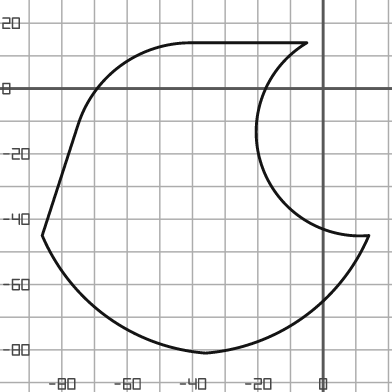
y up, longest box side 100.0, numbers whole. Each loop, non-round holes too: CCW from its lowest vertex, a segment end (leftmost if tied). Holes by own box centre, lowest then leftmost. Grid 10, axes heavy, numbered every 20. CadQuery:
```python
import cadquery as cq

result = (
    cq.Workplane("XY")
    .moveTo(-36.0, -81.0)
    .threePointArc((-6.0, -70.0), (14.0, -45.0))
    .threePointArc((-19.0, -23.0), (-5.0, 14.0))
    .lineTo(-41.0, 14.0)
    .threePointArc((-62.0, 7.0), (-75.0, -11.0))
    .lineTo(-86.0, -45.0)
    .threePointArc((-66.0, -70.0), (-36.0, -81.0))
    .close()
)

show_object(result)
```